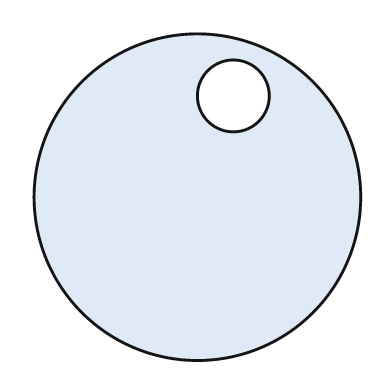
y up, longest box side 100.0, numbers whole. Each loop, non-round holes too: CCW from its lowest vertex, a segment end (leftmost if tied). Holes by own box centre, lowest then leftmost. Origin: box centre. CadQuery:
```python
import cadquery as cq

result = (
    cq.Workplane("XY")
    .moveTo(0.0, 0.0)
    .circle(50.0)
    .moveTo(11.0, 31.0)
    .circle(11.0)
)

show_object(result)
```